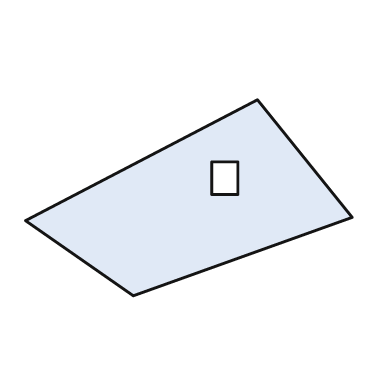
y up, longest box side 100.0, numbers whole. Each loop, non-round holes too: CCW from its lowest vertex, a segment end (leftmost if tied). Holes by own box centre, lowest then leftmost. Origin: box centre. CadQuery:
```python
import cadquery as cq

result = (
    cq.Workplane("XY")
    .moveTo(-17.0, -30.0)
    .lineTo(50.0, -6.0)
    .lineTo(21.0, 30.0)
    .lineTo(-50.0, -7.0)
    .close()
    .moveTo(7.0, 1.0)
    .lineTo(15.0, 1.0)
    .lineTo(15.0, 11.0)
    .lineTo(7.0, 11.0)
    .close()
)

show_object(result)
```